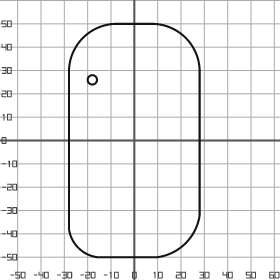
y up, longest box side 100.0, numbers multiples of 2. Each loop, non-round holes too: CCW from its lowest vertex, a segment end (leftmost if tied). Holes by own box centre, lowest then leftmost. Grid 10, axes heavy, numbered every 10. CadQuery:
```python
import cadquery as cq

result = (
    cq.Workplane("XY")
    .moveTo(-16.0, -50.0)
    .lineTo(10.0, -50.0)
    .threePointArc((22.0, -44.0), (28.0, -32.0))
    .lineTo(28.0, 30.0)
    .threePointArc((22.0, 44.0), (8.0, 50.0))
    .lineTo(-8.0, 50.0)
    .threePointArc((-22.0, 44.0), (-28.0, 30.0))
    .lineTo(-28.0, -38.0)
    .threePointArc((-24.0, -46.0), (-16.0, -50.0))
    .close()
    .moveTo(-18.0, 26.0)
    .circle(2.0)
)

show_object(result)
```